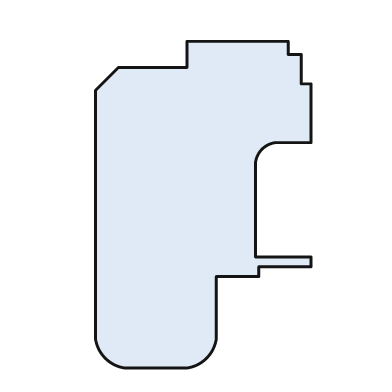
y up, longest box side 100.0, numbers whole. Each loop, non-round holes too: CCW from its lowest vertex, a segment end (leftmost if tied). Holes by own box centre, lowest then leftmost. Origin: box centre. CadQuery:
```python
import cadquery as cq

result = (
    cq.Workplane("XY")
    .moveTo(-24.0, -50.0)
    .lineTo(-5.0, -50.0)
    .threePointArc((1.0, -47.0), (4.0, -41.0))
    .lineTo(4.0, -22.0)
    .lineTo(17.0, -22.0)
    .lineTo(17.0, -19.0)
    .lineTo(33.0, -19.0)
    .lineTo(33.0, -16.0)
    .lineTo(16.0, -16.0)
    .lineTo(16.0, 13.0)
    .threePointArc((18.0, 17.0), (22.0, 19.0))
    .lineTo(33.0, 19.0)
    .lineTo(33.0, 37.0)
    .lineTo(30.0, 37.0)
    .lineTo(30.0, 46.0)
    .lineTo(26.0, 46.0)
    .lineTo(26.0, 50.0)
    .lineTo(-5.0, 50.0)
    .lineTo(-5.0, 42.0)
    .lineTo(-26.0, 42.0)
    .lineTo(-33.0, 35.0)
    .lineTo(-33.0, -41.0)
    .threePointArc((-30.0, -47.0), (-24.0, -50.0))
    .close()
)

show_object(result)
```